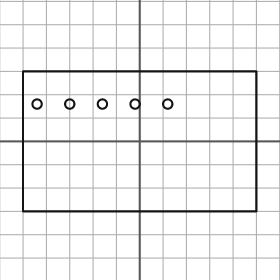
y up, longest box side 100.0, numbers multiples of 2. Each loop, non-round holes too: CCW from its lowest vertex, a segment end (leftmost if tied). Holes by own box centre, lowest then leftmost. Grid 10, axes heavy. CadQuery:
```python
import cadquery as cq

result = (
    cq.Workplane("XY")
    .moveTo(-50.0, -30.0)
    .lineTo(50.0, -30.0)
    .lineTo(50.0, 30.0)
    .lineTo(-50.0, 30.0)
    .close()
    .moveTo(-44.0, 16.0)
    .circle(2.0)
    .moveTo(-30.0, 16.0)
    .circle(2.0)
    .moveTo(-16.0, 16.0)
    .circle(2.0)
    .moveTo(-2.0, 16.0)
    .circle(2.0)
    .moveTo(12.0, 16.0)
    .circle(2.0)
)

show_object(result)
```